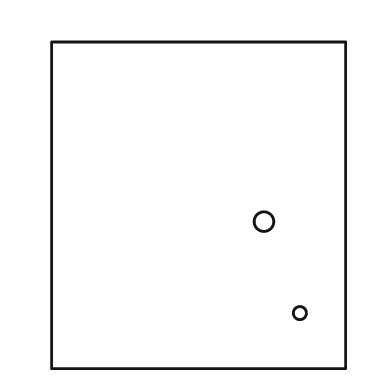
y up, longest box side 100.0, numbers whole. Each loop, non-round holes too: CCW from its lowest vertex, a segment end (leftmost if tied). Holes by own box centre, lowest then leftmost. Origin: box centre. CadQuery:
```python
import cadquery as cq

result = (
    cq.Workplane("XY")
    .moveTo(-45.0, -50.0)
    .lineTo(45.0, -50.0)
    .lineTo(45.0, 50.0)
    .lineTo(-45.0, 50.0)
    .close()
    .moveTo(31.0, -33.0)
    .circle(2.0)
    .moveTo(20.0, -5.0)
    .circle(3.0)
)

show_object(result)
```